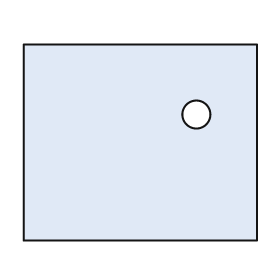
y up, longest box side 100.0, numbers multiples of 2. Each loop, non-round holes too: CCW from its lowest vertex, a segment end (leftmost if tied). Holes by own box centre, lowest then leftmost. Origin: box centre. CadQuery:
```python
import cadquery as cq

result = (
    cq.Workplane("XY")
    .moveTo(-50.0, -42.0)
    .lineTo(50.0, -42.0)
    .lineTo(50.0, 42.0)
    .lineTo(-50.0, 42.0)
    .close()
    .moveTo(24.0, 12.0)
    .circle(6.0)
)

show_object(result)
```